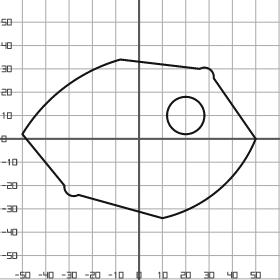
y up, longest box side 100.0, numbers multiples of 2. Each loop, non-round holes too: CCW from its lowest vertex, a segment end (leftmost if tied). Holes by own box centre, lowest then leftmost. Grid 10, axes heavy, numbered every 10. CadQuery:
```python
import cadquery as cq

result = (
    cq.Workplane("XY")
    .moveTo(10.0, -34.0)
    .threePointArc((34.0, -22.0), (50.0, 0.0))
    .lineTo(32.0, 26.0)
    .threePointArc((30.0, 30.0), (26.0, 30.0))
    .lineTo(-8.0, 34.0)
    .threePointArc((-32.0, 22.0), (-50.0, 2.0))
    .lineTo(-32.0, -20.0)
    .threePointArc((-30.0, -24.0), (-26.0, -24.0))
    .close()
    .moveTo(20.0, 10.0)
    .circle(8.0)
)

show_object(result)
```